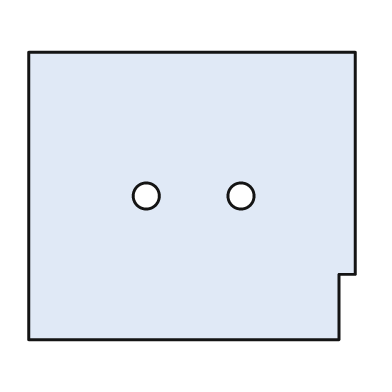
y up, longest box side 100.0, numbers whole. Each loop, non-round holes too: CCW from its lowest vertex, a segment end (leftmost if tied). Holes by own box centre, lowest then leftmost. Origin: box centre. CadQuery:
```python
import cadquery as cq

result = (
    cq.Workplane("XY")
    .moveTo(-50.0, -44.0)
    .lineTo(45.0, -44.0)
    .lineTo(45.0, -24.0)
    .lineTo(50.0, -24.0)
    .lineTo(50.0, 44.0)
    .lineTo(-50.0, 44.0)
    .close()
    .moveTo(-14.0, 0.0)
    .circle(4.0)
    .moveTo(15.0, 0.0)
    .circle(4.0)
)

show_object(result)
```